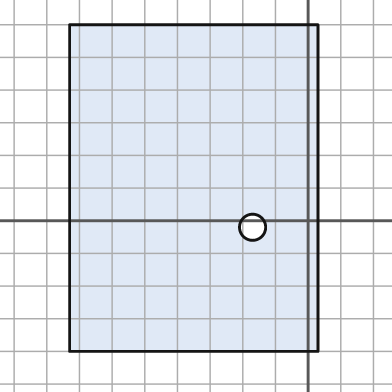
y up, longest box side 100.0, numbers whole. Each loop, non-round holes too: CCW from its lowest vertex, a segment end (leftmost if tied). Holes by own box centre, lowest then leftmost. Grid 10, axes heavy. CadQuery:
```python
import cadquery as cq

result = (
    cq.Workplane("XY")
    .moveTo(-73.0, -40.0)
    .lineTo(3.0, -40.0)
    .lineTo(3.0, 60.0)
    .lineTo(-73.0, 60.0)
    .close()
    .moveTo(-17.0, -2.0)
    .circle(4.0)
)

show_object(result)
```